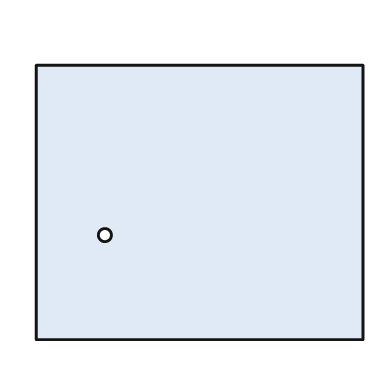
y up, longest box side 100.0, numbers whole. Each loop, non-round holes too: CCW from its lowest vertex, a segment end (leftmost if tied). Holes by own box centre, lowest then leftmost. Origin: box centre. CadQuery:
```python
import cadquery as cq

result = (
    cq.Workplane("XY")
    .moveTo(-50.0, -42.0)
    .lineTo(50.0, -42.0)
    .lineTo(50.0, 42.0)
    .lineTo(-50.0, 42.0)
    .close()
    .moveTo(-29.0, -10.0)
    .circle(2.0)
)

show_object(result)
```